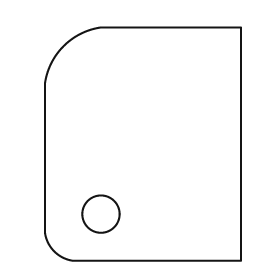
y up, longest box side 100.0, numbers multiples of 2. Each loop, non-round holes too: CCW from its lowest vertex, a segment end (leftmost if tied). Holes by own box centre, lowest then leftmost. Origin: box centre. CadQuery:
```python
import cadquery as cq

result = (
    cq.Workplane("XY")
    .moveTo(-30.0, -50.0)
    .lineTo(42.0, -50.0)
    .lineTo(42.0, 50.0)
    .lineTo(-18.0, 50.0)
    .threePointArc((-34.0, 42.0), (-42.0, 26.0))
    .lineTo(-42.0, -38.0)
    .threePointArc((-38.0, -46.0), (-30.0, -50.0))
    .close()
    .moveTo(-18.0, -30.0)
    .circle(8.0)
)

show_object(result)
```